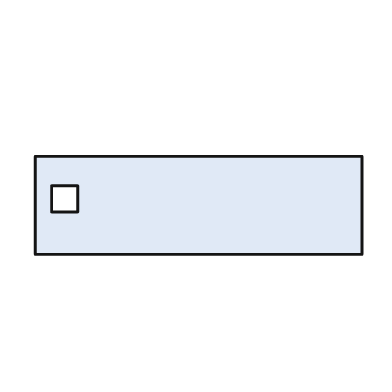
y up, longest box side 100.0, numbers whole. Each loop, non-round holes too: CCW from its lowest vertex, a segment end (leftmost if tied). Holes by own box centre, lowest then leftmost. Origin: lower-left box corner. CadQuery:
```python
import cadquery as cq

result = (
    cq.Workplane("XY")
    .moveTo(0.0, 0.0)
    .lineTo(100.0, 0.0)
    .lineTo(100.0, 30.0)
    .lineTo(0.0, 30.0)
    .close()
    .moveTo(5.0, 13.0)
    .lineTo(13.0, 13.0)
    .lineTo(13.0, 21.0)
    .lineTo(5.0, 21.0)
    .close()
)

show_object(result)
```